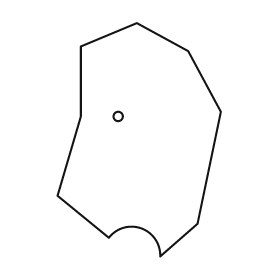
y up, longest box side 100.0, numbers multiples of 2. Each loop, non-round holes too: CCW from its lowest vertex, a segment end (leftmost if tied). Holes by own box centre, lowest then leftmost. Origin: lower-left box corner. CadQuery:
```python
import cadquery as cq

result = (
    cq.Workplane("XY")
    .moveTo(44.0, 0.0)
    .lineTo(60.0, 14.0)
    .lineTo(70.0, 62.0)
    .lineTo(56.0, 88.0)
    .lineTo(34.0, 100.0)
    .lineTo(10.0, 90.0)
    .lineTo(10.0, 60.0)
    .lineTo(0.0, 26.0)
    .lineTo(22.0, 8.0)
    .threePointArc((36.0, 12.0), (44.0, 0.0))
    .close()
    .moveTo(26.0, 60.0)
    .circle(2.0)
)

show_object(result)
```